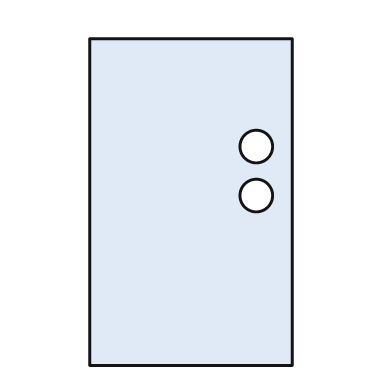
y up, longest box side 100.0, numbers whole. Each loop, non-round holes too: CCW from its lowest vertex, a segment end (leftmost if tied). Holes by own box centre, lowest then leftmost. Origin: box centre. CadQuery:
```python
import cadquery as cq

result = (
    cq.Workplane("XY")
    .moveTo(-31.0, -50.0)
    .lineTo(31.0, -50.0)
    .lineTo(31.0, 50.0)
    .lineTo(-31.0, 50.0)
    .close()
    .moveTo(20.0, 2.0)
    .circle(5.0)
    .moveTo(20.0, 17.0)
    .circle(5.0)
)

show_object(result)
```